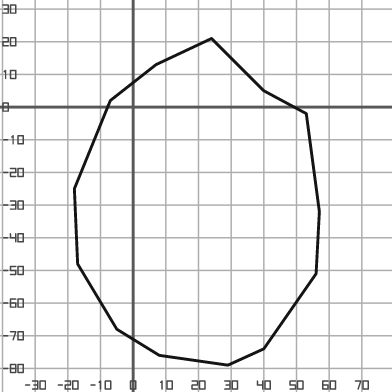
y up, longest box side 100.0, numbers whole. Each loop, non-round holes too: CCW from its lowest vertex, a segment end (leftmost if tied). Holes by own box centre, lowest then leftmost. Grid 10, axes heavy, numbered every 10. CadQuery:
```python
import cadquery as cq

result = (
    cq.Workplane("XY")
    .moveTo(29.0, -79.0)
    .lineTo(40.0, -74.0)
    .lineTo(56.0, -51.0)
    .lineTo(57.0, -32.0)
    .lineTo(53.0, -2.0)
    .lineTo(40.0, 5.0)
    .lineTo(24.0, 21.0)
    .lineTo(7.0, 13.0)
    .lineTo(-7.0, 2.0)
    .lineTo(-18.0, -25.0)
    .lineTo(-17.0, -48.0)
    .lineTo(-5.0, -68.0)
    .lineTo(8.0, -76.0)
    .close()
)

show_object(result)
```